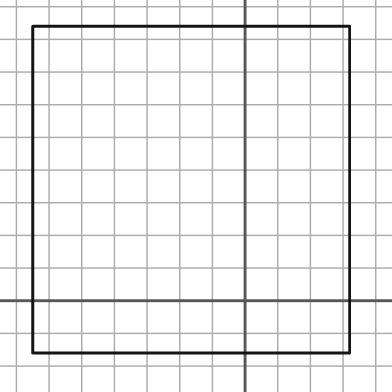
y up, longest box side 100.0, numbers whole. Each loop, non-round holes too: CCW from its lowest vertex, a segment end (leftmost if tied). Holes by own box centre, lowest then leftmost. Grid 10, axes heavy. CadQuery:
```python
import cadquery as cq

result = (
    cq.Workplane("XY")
    .moveTo(-65.0, -16.0)
    .lineTo(32.0, -16.0)
    .lineTo(32.0, 84.0)
    .lineTo(-65.0, 84.0)
    .close()
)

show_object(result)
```